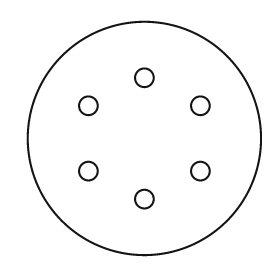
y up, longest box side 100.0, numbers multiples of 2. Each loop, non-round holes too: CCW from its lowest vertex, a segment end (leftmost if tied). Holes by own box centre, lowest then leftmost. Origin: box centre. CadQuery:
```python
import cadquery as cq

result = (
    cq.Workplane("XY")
    .moveTo(0.0, 0.0)
    .circle(50.0)
    .moveTo(0.0, -26.0)
    .circle(4.0)
    .moveTo(-24.0, -14.0)
    .circle(4.0)
    .moveTo(24.0, -14.0)
    .circle(4.0)
    .moveTo(-24.0, 14.0)
    .circle(4.0)
    .moveTo(24.0, 14.0)
    .circle(4.0)
    .moveTo(0.0, 26.0)
    .circle(4.0)
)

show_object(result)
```